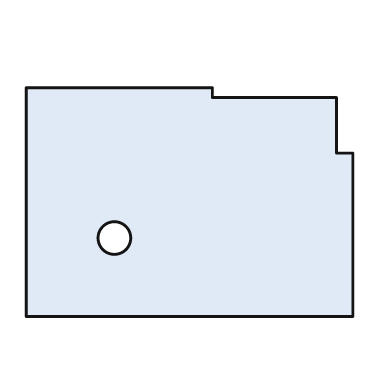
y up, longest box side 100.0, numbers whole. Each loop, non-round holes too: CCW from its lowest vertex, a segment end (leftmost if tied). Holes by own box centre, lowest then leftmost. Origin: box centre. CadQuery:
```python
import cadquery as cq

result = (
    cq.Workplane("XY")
    .moveTo(-50.0, -35.0)
    .lineTo(50.0, -35.0)
    .lineTo(50.0, 15.0)
    .lineTo(45.0, 15.0)
    .lineTo(45.0, 32.0)
    .lineTo(7.0, 32.0)
    .lineTo(7.0, 35.0)
    .lineTo(-50.0, 35.0)
    .close()
    .moveTo(-23.0, -11.0)
    .circle(5.0)
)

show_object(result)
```